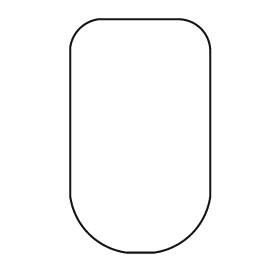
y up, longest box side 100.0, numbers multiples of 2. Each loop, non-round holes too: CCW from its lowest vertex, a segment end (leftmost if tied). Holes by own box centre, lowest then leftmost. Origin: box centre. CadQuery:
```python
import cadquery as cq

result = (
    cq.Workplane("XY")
    .moveTo(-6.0, -50.0)
    .lineTo(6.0, -50.0)
    .threePointArc((22.0, -42.0), (30.0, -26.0))
    .lineTo(30.0, 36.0)
    .threePointArc((26.0, 46.0), (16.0, 50.0))
    .lineTo(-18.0, 50.0)
    .threePointArc((-26.0, 46.0), (-30.0, 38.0))
    .lineTo(-30.0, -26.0)
    .threePointArc((-22.0, -42.0), (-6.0, -50.0))
    .close()
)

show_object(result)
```